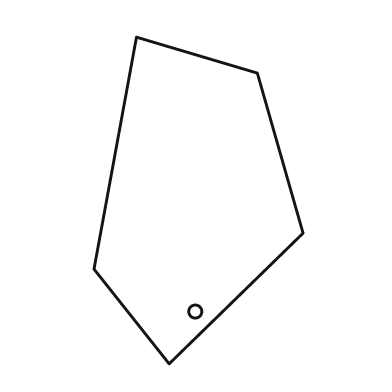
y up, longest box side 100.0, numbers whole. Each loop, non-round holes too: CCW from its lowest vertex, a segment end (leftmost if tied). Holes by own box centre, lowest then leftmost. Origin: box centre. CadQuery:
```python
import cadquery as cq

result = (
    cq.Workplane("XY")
    .moveTo(-9.0, -50.0)
    .lineTo(32.0, -10.0)
    .lineTo(18.0, 39.0)
    .lineTo(-19.0, 50.0)
    .lineTo(-32.0, -21.0)
    .close()
    .moveTo(-1.0, -34.0)
    .circle(2.0)
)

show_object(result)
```